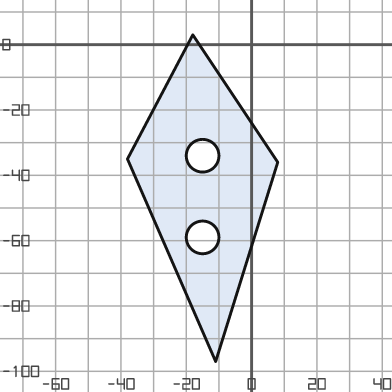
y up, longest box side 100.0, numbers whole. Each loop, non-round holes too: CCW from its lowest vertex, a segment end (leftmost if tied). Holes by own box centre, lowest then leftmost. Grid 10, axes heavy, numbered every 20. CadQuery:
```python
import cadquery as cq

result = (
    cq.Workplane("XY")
    .moveTo(-11.0, -97.0)
    .lineTo(8.0, -36.0)
    .lineTo(-18.0, 3.0)
    .lineTo(-38.0, -35.0)
    .close()
    .moveTo(-15.0, -59.0)
    .circle(5.0)
    .moveTo(-15.0, -34.0)
    .circle(5.0)
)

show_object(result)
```